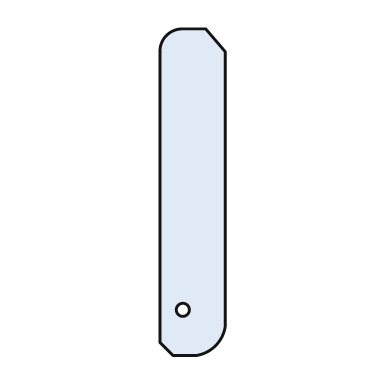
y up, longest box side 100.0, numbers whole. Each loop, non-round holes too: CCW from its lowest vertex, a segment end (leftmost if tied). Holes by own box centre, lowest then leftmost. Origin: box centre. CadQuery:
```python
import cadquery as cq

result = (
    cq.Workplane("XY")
    .moveTo(-6.0, -50.0)
    .lineTo(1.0, -50.0)
    .threePointArc((7.0, -47.0), (10.0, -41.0))
    .lineTo(10.0, 43.0)
    .lineTo(4.0, 50.0)
    .lineTo(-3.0, 50.0)
    .threePointArc((-8.0, 48.0), (-10.0, 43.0))
    .lineTo(-10.0, -46.0)
    .close()
    .moveTo(-3.0, -36.0)
    .circle(2.0)
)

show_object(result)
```